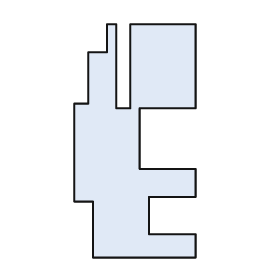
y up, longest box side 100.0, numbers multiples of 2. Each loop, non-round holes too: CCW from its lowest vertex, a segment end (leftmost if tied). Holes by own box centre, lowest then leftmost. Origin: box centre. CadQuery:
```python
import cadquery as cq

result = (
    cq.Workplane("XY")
    .moveTo(-18.0, -50.0)
    .lineTo(26.0, -50.0)
    .lineTo(26.0, -40.0)
    .lineTo(6.0, -40.0)
    .lineTo(6.0, -24.0)
    .lineTo(26.0, -24.0)
    .lineTo(26.0, -12.0)
    .lineTo(2.0, -12.0)
    .lineTo(2.0, 14.0)
    .lineTo(26.0, 14.0)
    .lineTo(26.0, 50.0)
    .lineTo(-2.0, 50.0)
    .lineTo(-2.0, 14.0)
    .lineTo(-8.0, 14.0)
    .lineTo(-8.0, 50.0)
    .lineTo(-12.0, 50.0)
    .lineTo(-12.0, 38.0)
    .lineTo(-20.0, 38.0)
    .lineTo(-20.0, 16.0)
    .lineTo(-26.0, 16.0)
    .lineTo(-26.0, -26.0)
    .lineTo(-18.0, -26.0)
    .close()
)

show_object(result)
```